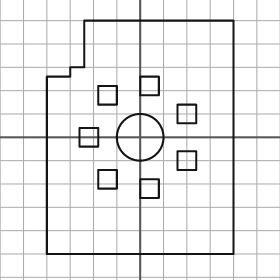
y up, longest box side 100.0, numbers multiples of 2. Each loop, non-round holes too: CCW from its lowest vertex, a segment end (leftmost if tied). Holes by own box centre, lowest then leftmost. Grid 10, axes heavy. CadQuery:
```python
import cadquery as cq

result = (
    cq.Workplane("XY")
    .moveTo(-40.0, -50.0)
    .lineTo(40.0, -50.0)
    .lineTo(40.0, 50.0)
    .lineTo(-24.0, 50.0)
    .lineTo(-24.0, 30.0)
    .lineTo(-30.0, 30.0)
    .lineTo(-30.0, 26.0)
    .lineTo(-40.0, 26.0)
    .close()
    .moveTo(0.0, -26.0)
    .lineTo(8.0, -26.0)
    .lineTo(8.0, -18.0)
    .lineTo(0.0, -18.0)
    .close()
    .moveTo(-18.0, -22.0)
    .lineTo(-10.0, -22.0)
    .lineTo(-10.0, -14.0)
    .lineTo(-18.0, -14.0)
    .close()
    .moveTo(16.0, -14.0)
    .lineTo(24.0, -14.0)
    .lineTo(24.0, -6.0)
    .lineTo(16.0, -6.0)
    .close()
    .moveTo(-26.0, -4.0)
    .lineTo(-18.0, -4.0)
    .lineTo(-18.0, 4.0)
    .lineTo(-26.0, 4.0)
    .close()
    .moveTo(0.0, 0.0)
    .circle(10.0)
    .moveTo(16.0, 6.0)
    .lineTo(24.0, 6.0)
    .lineTo(24.0, 14.0)
    .lineTo(16.0, 14.0)
    .close()
    .moveTo(-18.0, 14.0)
    .lineTo(-10.0, 14.0)
    .lineTo(-10.0, 22.0)
    .lineTo(-18.0, 22.0)
    .close()
    .moveTo(0.0, 18.0)
    .lineTo(8.0, 18.0)
    .lineTo(8.0, 26.0)
    .lineTo(0.0, 26.0)
    .close()
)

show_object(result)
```